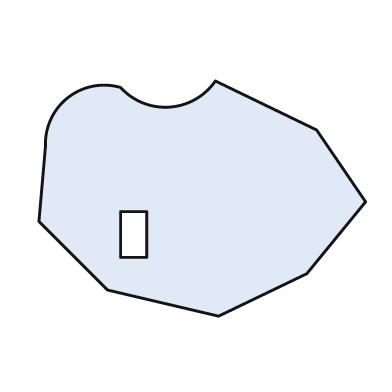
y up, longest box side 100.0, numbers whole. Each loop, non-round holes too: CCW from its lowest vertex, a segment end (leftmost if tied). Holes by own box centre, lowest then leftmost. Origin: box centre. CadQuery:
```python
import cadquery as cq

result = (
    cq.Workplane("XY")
    .moveTo(5.0, -36.0)
    .lineTo(32.0, -23.0)
    .lineTo(50.0, -1.0)
    .lineTo(35.0, 21.0)
    .lineTo(4.0, 36.0)
    .threePointArc((-10.0, 28.0), (-25.0, 34.0))
    .threePointArc((-41.0, 31.0), (-48.0, 16.0))
    .lineTo(-50.0, -7.0)
    .lineTo(-29.0, -28.0)
    .close()
    .moveTo(-25.0, -18.0)
    .lineTo(-17.0, -18.0)
    .lineTo(-17.0, -4.0)
    .lineTo(-25.0, -4.0)
    .close()
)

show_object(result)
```